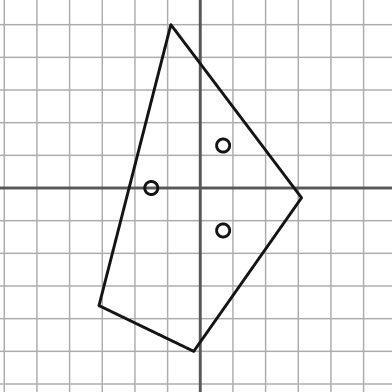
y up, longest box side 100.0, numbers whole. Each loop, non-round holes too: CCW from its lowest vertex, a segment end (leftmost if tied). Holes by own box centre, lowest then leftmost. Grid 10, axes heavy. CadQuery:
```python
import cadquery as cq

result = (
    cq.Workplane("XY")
    .moveTo(-2.0, -50.0)
    .lineTo(31.0, -3.0)
    .lineTo(-9.0, 50.0)
    .lineTo(-31.0, -36.0)
    .close()
    .moveTo(7.0, -13.0)
    .circle(2.0)
    .moveTo(-15.0, 0.0)
    .circle(2.0)
    .moveTo(7.0, 13.0)
    .circle(2.0)
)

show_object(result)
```